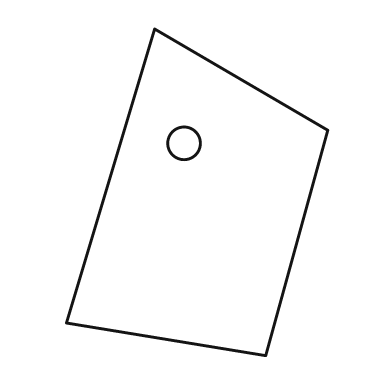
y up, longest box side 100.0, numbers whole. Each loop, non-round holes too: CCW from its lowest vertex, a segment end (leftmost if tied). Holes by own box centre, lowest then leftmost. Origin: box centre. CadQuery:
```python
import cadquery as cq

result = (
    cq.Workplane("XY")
    .moveTo(21.0, -50.0)
    .lineTo(40.0, 19.0)
    .lineTo(-13.0, 50.0)
    .lineTo(-40.0, -40.0)
    .close()
    .moveTo(-4.0, 15.0)
    .circle(5.0)
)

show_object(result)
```